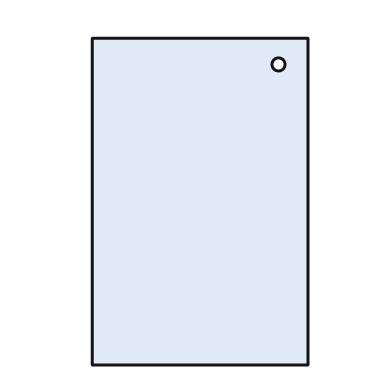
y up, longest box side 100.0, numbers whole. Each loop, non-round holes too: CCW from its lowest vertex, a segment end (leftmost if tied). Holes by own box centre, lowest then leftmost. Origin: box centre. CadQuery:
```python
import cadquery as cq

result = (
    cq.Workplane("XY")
    .moveTo(-33.0, -50.0)
    .lineTo(33.0, -50.0)
    .lineTo(33.0, 50.0)
    .lineTo(-33.0, 50.0)
    .close()
    .moveTo(24.0, 42.0)
    .circle(2.0)
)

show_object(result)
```